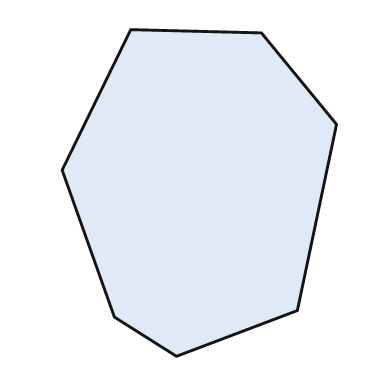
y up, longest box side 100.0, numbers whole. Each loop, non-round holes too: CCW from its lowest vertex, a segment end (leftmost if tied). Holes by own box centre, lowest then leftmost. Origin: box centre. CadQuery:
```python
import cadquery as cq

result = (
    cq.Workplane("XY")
    .moveTo(-7.0, -50.0)
    .lineTo(30.0, -36.0)
    .lineTo(42.0, 21.0)
    .lineTo(19.0, 49.0)
    .lineTo(-21.0, 50.0)
    .lineTo(-42.0, 7.0)
    .lineTo(-26.0, -38.0)
    .close()
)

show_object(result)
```